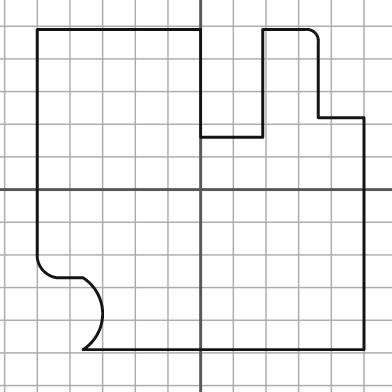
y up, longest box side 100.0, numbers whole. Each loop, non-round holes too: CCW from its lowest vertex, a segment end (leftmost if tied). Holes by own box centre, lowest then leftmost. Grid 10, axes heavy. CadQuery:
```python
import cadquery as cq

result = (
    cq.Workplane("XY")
    .moveTo(-36.0, -49.0)
    .lineTo(50.0, -49.0)
    .lineTo(50.0, 22.0)
    .lineTo(36.0, 22.0)
    .lineTo(36.0, 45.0)
    .threePointArc((35.0, 48.0), (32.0, 49.0))
    .lineTo(19.0, 49.0)
    .lineTo(19.0, 16.0)
    .lineTo(0.0, 16.0)
    .lineTo(0.0, 49.0)
    .lineTo(-50.0, 49.0)
    .lineTo(-50.0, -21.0)
    .threePointArc((-48.0, -25.0), (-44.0, -27.0))
    .lineTo(-36.0, -27.0)
    .threePointArc((-30.0, -38.0), (-36.0, -49.0))
    .close()
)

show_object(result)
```